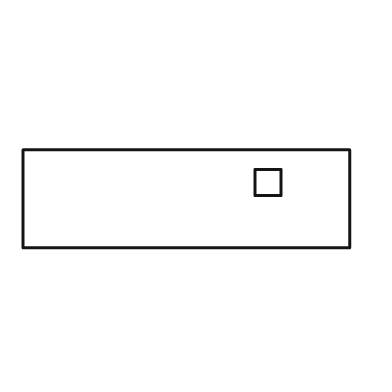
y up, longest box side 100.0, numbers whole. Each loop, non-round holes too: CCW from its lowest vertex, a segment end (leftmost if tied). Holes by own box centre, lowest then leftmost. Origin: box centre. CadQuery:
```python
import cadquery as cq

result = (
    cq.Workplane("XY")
    .moveTo(-50.0, -15.0)
    .lineTo(50.0, -15.0)
    .lineTo(50.0, 15.0)
    .lineTo(-50.0, 15.0)
    .close()
    .moveTo(21.0, 1.0)
    .lineTo(29.0, 1.0)
    .lineTo(29.0, 9.0)
    .lineTo(21.0, 9.0)
    .close()
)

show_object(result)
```